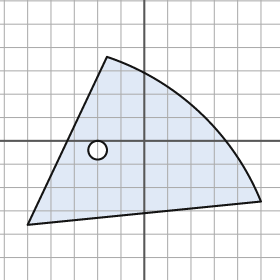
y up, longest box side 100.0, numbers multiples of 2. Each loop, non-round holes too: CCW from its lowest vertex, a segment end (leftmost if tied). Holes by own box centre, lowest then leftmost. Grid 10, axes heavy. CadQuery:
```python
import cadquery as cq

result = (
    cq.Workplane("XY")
    .moveTo(-50.0, -36.0)
    .lineTo(50.0, -26.0)
    .threePointArc((24.0, 12.0), (-16.0, 36.0))
    .close()
    .moveTo(-20.0, -4.0)
    .circle(4.0)
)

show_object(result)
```